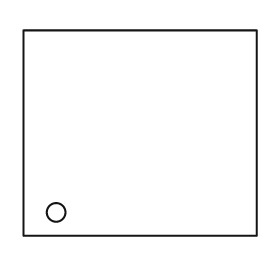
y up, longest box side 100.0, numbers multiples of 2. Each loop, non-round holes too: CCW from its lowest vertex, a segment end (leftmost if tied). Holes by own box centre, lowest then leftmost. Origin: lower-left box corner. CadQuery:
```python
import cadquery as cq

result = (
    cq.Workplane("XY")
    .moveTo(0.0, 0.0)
    .lineTo(100.0, 0.0)
    .lineTo(100.0, 88.0)
    .lineTo(0.0, 88.0)
    .close()
    .moveTo(14.0, 10.0)
    .circle(4.0)
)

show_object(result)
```